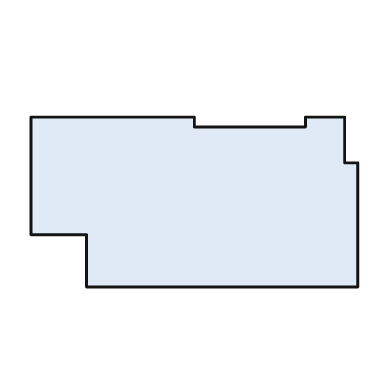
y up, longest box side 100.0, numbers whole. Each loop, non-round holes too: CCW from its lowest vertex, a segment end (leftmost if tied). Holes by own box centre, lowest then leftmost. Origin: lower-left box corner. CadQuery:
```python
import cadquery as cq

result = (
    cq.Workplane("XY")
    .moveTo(17.0, 0.0)
    .lineTo(100.0, 0.0)
    .lineTo(100.0, 38.0)
    .lineTo(96.0, 38.0)
    .lineTo(96.0, 52.0)
    .lineTo(84.0, 52.0)
    .lineTo(84.0, 49.0)
    .lineTo(50.0, 49.0)
    .lineTo(50.0, 52.0)
    .lineTo(0.0, 52.0)
    .lineTo(0.0, 16.0)
    .lineTo(17.0, 16.0)
    .close()
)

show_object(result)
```